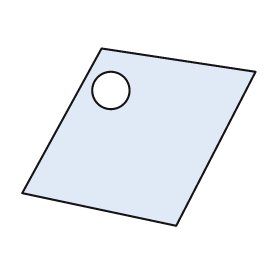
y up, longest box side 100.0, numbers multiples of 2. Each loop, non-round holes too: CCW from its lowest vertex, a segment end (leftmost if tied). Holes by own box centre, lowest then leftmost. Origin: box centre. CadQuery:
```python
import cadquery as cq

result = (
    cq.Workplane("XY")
    .moveTo(16.0, -38.0)
    .lineTo(50.0, 28.0)
    .lineTo(-16.0, 38.0)
    .lineTo(-50.0, -24.0)
    .close()
    .moveTo(-12.0, 20.0)
    .circle(8.0)
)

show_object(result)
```